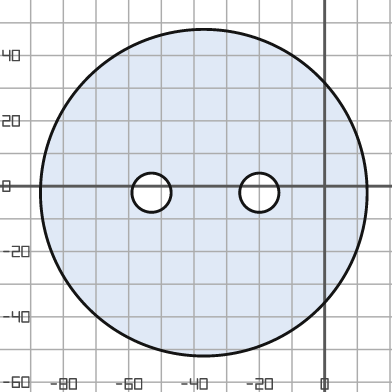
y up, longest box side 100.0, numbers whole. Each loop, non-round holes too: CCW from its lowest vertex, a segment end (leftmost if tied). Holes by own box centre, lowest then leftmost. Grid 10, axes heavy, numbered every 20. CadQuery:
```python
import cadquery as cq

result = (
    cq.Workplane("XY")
    .moveTo(-37.0, -2.0)
    .circle(50.0)
    .moveTo(-53.0, -2.0)
    .circle(6.0)
    .moveTo(-20.0, -2.0)
    .circle(6.0)
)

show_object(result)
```